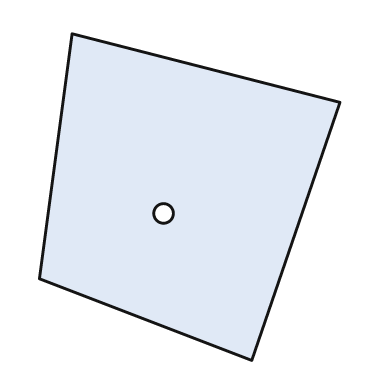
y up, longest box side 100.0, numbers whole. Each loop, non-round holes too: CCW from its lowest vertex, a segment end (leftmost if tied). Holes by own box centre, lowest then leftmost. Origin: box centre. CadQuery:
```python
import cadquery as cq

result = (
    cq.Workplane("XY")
    .moveTo(19.0, -50.0)
    .lineTo(46.0, 29.0)
    .lineTo(-36.0, 50.0)
    .lineTo(-46.0, -25.0)
    .close()
    .moveTo(-8.0, -5.0)
    .circle(3.0)
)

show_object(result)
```